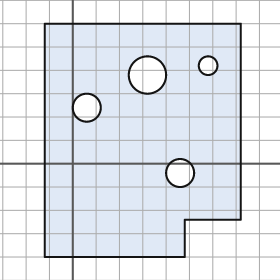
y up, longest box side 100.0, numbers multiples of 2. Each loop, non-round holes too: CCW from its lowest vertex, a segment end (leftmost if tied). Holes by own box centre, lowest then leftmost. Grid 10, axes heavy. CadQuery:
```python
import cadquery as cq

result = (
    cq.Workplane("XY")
    .moveTo(-12.0, -40.0)
    .lineTo(48.0, -40.0)
    .lineTo(48.0, -24.0)
    .lineTo(72.0, -24.0)
    .lineTo(72.0, 60.0)
    .lineTo(-12.0, 60.0)
    .close()
    .moveTo(46.0, -4.0)
    .circle(6.0)
    .moveTo(6.0, 24.0)
    .circle(6.0)
    .moveTo(32.0, 38.0)
    .circle(8.0)
    .moveTo(58.0, 42.0)
    .circle(4.0)
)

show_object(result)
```